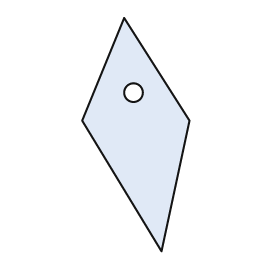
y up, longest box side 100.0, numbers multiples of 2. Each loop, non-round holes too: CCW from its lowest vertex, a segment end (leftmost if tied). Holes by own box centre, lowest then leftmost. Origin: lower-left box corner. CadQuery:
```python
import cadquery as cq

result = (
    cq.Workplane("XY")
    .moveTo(34.0, 0.0)
    .lineTo(46.0, 56.0)
    .lineTo(18.0, 100.0)
    .lineTo(0.0, 56.0)
    .close()
    .moveTo(22.0, 68.0)
    .circle(4.0)
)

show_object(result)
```